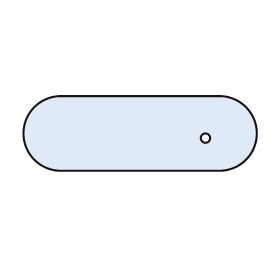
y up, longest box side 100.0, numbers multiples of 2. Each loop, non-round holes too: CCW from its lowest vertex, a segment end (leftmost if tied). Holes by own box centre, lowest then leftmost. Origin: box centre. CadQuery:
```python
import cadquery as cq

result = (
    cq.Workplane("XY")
    .moveTo(-34.0, -16.0)
    .lineTo(34.0, -16.0)
    .threePointArc((50.0, 0.0), (34.0, 16.0))
    .lineTo(-34.0, 16.0)
    .threePointArc((-50.0, 0.0), (-34.0, -16.0))
    .close()
    .moveTo(28.0, -2.0)
    .circle(2.0)
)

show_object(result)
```